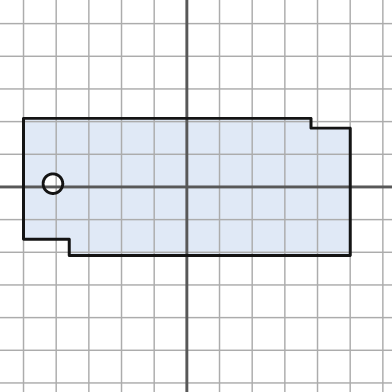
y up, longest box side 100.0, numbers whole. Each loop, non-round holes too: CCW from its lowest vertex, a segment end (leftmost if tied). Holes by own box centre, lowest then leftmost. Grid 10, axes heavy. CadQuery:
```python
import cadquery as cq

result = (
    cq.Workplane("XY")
    .moveTo(-36.0, -21.0)
    .lineTo(50.0, -21.0)
    .lineTo(50.0, 18.0)
    .lineTo(38.0, 18.0)
    .lineTo(38.0, 21.0)
    .lineTo(-50.0, 21.0)
    .lineTo(-50.0, -16.0)
    .lineTo(-36.0, -16.0)
    .close()
    .moveTo(-41.0, 1.0)
    .circle(3.0)
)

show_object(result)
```